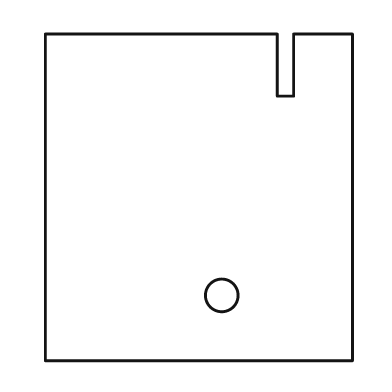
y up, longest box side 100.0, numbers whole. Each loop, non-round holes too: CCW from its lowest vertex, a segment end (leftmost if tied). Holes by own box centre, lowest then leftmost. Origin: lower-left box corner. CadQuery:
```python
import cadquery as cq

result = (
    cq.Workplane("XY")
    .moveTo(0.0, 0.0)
    .lineTo(94.0, 0.0)
    .lineTo(94.0, 100.0)
    .lineTo(76.0, 100.0)
    .lineTo(76.0, 81.0)
    .lineTo(71.0, 81.0)
    .lineTo(71.0, 100.0)
    .lineTo(0.0, 100.0)
    .close()
    .moveTo(54.0, 20.0)
    .circle(5.0)
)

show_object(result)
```